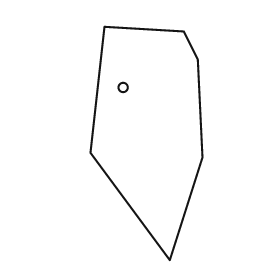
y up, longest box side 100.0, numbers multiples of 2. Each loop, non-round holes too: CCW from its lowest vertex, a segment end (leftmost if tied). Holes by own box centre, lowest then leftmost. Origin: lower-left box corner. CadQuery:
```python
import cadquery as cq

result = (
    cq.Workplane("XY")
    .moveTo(34.0, 0.0)
    .lineTo(48.0, 44.0)
    .lineTo(46.0, 86.0)
    .lineTo(40.0, 98.0)
    .lineTo(6.0, 100.0)
    .lineTo(0.0, 46.0)
    .close()
    .moveTo(14.0, 74.0)
    .circle(2.0)
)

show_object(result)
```